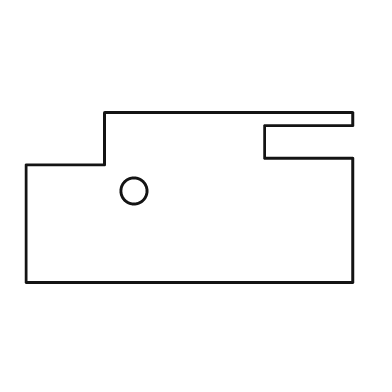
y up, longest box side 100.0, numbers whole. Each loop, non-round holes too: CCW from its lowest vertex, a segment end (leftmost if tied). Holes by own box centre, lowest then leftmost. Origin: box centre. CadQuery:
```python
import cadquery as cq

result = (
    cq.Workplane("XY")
    .moveTo(-50.0, -26.0)
    .lineTo(50.0, -26.0)
    .lineTo(50.0, 12.0)
    .lineTo(23.0, 12.0)
    .lineTo(23.0, 22.0)
    .lineTo(50.0, 22.0)
    .lineTo(50.0, 26.0)
    .lineTo(-26.0, 26.0)
    .lineTo(-26.0, 10.0)
    .lineTo(-50.0, 10.0)
    .close()
    .moveTo(-17.0, 2.0)
    .circle(4.0)
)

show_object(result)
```